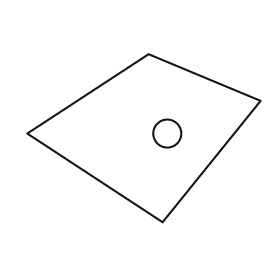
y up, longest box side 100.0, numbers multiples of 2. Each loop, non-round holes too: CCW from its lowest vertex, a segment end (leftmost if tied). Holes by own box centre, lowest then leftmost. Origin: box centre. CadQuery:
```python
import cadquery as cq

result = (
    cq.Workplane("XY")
    .moveTo(8.0, -36.0)
    .lineTo(50.0, 16.0)
    .lineTo(2.0, 36.0)
    .lineTo(-50.0, 2.0)
    .close()
    .moveTo(10.0, 2.0)
    .circle(6.0)
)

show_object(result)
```